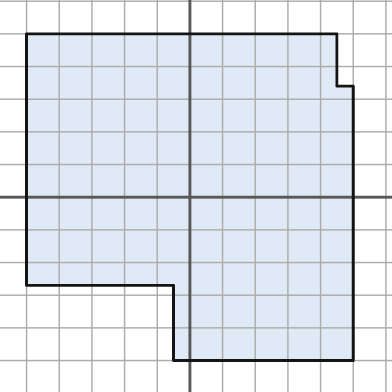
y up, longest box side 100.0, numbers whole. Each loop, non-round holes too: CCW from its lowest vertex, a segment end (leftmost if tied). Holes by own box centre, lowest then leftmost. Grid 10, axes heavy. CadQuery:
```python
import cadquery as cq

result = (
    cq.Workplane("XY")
    .moveTo(-5.0, -50.0)
    .lineTo(50.0, -50.0)
    .lineTo(50.0, 34.0)
    .lineTo(45.0, 34.0)
    .lineTo(45.0, 50.0)
    .lineTo(-50.0, 50.0)
    .lineTo(-50.0, -27.0)
    .lineTo(-5.0, -27.0)
    .close()
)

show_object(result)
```